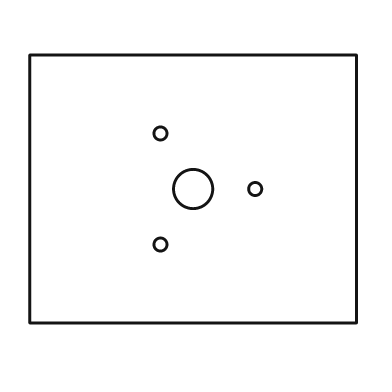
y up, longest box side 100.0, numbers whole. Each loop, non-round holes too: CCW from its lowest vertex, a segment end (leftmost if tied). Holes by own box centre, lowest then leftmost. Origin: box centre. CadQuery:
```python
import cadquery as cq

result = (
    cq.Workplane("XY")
    .moveTo(-50.0, -41.0)
    .lineTo(50.0, -41.0)
    .lineTo(50.0, 41.0)
    .lineTo(-50.0, 41.0)
    .close()
    .moveTo(-10.0, -17.0)
    .circle(2.0)
    .moveTo(0.0, 0.0)
    .circle(6.0)
    .moveTo(19.0, 0.0)
    .circle(2.0)
    .moveTo(-10.0, 17.0)
    .circle(2.0)
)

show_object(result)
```